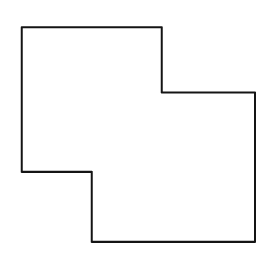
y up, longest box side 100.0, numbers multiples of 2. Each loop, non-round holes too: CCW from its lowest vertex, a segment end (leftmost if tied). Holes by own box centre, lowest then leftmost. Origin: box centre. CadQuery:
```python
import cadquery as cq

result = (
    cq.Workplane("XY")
    .moveTo(-20.0, -46.0)
    .lineTo(50.0, -46.0)
    .lineTo(50.0, 18.0)
    .lineTo(10.0, 18.0)
    .lineTo(10.0, 46.0)
    .lineTo(-50.0, 46.0)
    .lineTo(-50.0, -16.0)
    .lineTo(-20.0, -16.0)
    .close()
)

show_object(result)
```